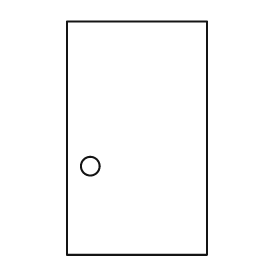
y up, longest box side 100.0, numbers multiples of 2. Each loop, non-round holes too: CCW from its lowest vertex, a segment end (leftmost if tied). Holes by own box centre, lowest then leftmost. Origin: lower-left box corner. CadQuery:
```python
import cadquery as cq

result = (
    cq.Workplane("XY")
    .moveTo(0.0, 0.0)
    .lineTo(60.0, 0.0)
    .lineTo(60.0, 100.0)
    .lineTo(0.0, 100.0)
    .close()
    .moveTo(10.0, 38.0)
    .circle(4.0)
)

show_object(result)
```